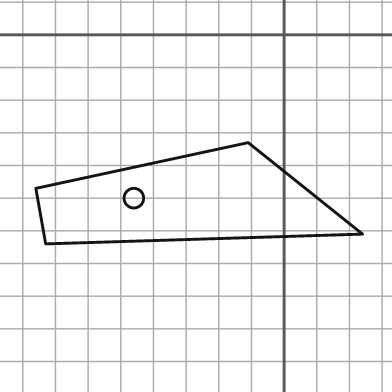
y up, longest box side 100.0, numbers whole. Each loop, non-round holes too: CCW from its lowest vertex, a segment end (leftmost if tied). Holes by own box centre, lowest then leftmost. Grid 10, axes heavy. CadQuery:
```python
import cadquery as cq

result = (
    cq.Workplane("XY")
    .moveTo(-73.0, -64.0)
    .lineTo(24.0, -61.0)
    .lineTo(-11.0, -33.0)
    .lineTo(-76.0, -47.0)
    .close()
    .moveTo(-46.0, -50.0)
    .circle(3.0)
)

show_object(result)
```